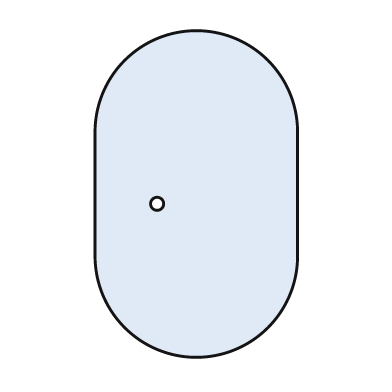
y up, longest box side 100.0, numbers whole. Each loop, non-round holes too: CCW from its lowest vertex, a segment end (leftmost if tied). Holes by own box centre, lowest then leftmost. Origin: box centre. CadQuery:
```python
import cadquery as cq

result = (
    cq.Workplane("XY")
    .moveTo(-31.0, -19.0)
    .threePointArc((0.0, -50.0), (31.0, -19.0))
    .lineTo(31.0, 19.0)
    .threePointArc((0.0, 50.0), (-31.0, 19.0))
    .close()
    .moveTo(-12.0, -3.0)
    .circle(2.0)
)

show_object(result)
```